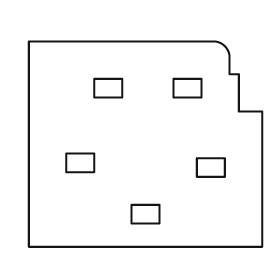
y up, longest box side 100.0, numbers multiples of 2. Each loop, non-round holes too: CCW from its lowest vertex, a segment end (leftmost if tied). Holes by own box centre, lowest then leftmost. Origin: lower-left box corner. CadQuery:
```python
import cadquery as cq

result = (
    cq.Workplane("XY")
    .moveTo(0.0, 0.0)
    .lineTo(100.0, 0.0)
    .lineTo(100.0, 58.0)
    .lineTo(90.0, 58.0)
    .lineTo(90.0, 74.0)
    .lineTo(86.0, 74.0)
    .lineTo(86.0, 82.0)
    .threePointArc((84.0, 86.0), (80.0, 88.0))
    .lineTo(0.0, 88.0)
    .close()
    .moveTo(44.0, 10.0)
    .lineTo(56.0, 10.0)
    .lineTo(56.0, 18.0)
    .lineTo(44.0, 18.0)
    .close()
    .moveTo(72.0, 30.0)
    .lineTo(84.0, 30.0)
    .lineTo(84.0, 38.0)
    .lineTo(72.0, 38.0)
    .close()
    .moveTo(16.0, 32.0)
    .lineTo(28.0, 32.0)
    .lineTo(28.0, 40.0)
    .lineTo(16.0, 40.0)
    .close()
    .moveTo(28.0, 64.0)
    .lineTo(40.0, 64.0)
    .lineTo(40.0, 72.0)
    .lineTo(28.0, 72.0)
    .close()
    .moveTo(62.0, 64.0)
    .lineTo(74.0, 64.0)
    .lineTo(74.0, 72.0)
    .lineTo(62.0, 72.0)
    .close()
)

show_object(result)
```